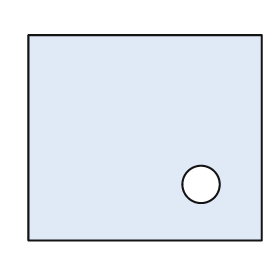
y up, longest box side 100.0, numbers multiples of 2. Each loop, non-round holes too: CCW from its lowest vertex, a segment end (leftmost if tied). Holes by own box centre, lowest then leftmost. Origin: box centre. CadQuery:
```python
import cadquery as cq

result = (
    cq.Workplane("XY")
    .moveTo(-50.0, -44.0)
    .lineTo(50.0, -44.0)
    .lineTo(50.0, 44.0)
    .lineTo(-50.0, 44.0)
    .close()
    .moveTo(24.0, -20.0)
    .circle(8.0)
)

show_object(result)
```